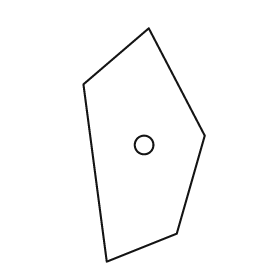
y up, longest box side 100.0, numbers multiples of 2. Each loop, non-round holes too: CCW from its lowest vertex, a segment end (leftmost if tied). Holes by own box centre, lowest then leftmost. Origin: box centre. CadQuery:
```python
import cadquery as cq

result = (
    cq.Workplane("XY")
    .moveTo(-16.0, -50.0)
    .lineTo(14.0, -38.0)
    .lineTo(26.0, 4.0)
    .lineTo(2.0, 50.0)
    .lineTo(-26.0, 26.0)
    .close()
    .moveTo(0.0, 0.0)
    .circle(4.0)
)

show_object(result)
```